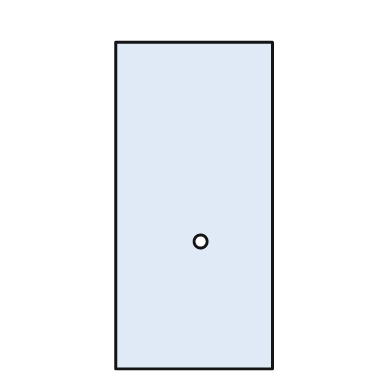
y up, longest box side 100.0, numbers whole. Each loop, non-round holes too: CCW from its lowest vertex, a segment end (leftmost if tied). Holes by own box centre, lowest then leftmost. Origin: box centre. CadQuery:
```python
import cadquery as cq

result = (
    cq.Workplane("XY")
    .moveTo(-24.0, -50.0)
    .lineTo(24.0, -50.0)
    .lineTo(24.0, 50.0)
    .lineTo(-24.0, 50.0)
    .close()
    .moveTo(2.0, -11.0)
    .circle(2.0)
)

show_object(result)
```